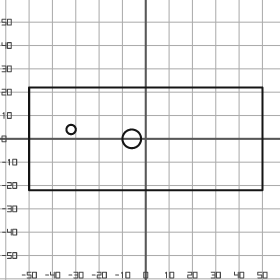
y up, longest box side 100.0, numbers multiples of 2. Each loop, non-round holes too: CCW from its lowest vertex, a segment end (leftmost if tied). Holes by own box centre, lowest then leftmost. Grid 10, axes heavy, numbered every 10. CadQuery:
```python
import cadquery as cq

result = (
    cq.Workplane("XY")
    .moveTo(-50.0, -22.0)
    .lineTo(50.0, -22.0)
    .lineTo(50.0, 22.0)
    .lineTo(-50.0, 22.0)
    .close()
    .moveTo(-6.0, 0.0)
    .circle(4.0)
    .moveTo(-32.0, 4.0)
    .circle(2.0)
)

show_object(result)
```